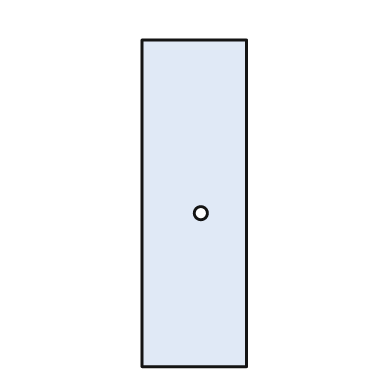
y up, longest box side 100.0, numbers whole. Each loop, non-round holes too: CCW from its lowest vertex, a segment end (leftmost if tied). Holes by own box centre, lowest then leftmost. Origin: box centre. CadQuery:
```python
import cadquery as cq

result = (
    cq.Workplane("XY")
    .moveTo(-16.0, -50.0)
    .lineTo(16.0, -50.0)
    .lineTo(16.0, 50.0)
    .lineTo(-16.0, 50.0)
    .close()
    .moveTo(2.0, -3.0)
    .circle(2.0)
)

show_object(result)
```